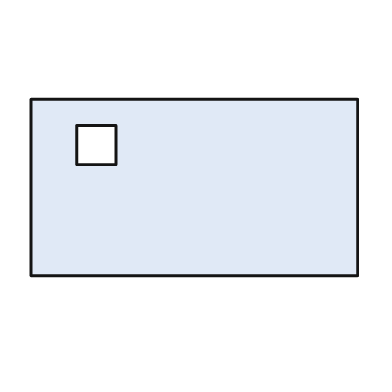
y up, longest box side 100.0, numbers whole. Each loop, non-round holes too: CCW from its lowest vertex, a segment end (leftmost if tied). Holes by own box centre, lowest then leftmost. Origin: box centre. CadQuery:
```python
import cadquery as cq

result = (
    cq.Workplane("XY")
    .moveTo(-50.0, -27.0)
    .lineTo(50.0, -27.0)
    .lineTo(50.0, 27.0)
    .lineTo(-50.0, 27.0)
    .close()
    .moveTo(-36.0, 7.0)
    .lineTo(-24.0, 7.0)
    .lineTo(-24.0, 19.0)
    .lineTo(-36.0, 19.0)
    .close()
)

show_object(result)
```